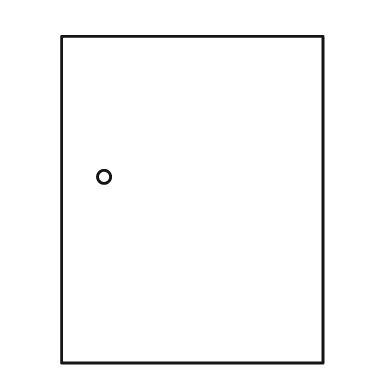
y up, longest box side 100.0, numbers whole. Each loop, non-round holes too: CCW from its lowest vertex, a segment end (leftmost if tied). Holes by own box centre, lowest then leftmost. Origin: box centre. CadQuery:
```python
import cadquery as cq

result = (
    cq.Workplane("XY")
    .moveTo(-40.0, -50.0)
    .lineTo(40.0, -50.0)
    .lineTo(40.0, 50.0)
    .lineTo(-40.0, 50.0)
    .close()
    .moveTo(-27.0, 7.0)
    .circle(2.0)
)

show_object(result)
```